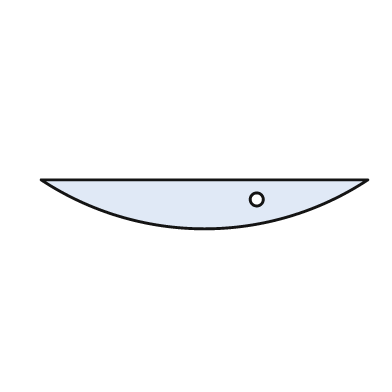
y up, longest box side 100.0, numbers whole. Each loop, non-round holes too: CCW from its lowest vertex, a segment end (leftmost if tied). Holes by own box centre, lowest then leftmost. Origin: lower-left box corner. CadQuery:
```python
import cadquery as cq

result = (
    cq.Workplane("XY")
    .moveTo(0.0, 15.0)
    .threePointArc((50.0, 0.0), (100.0, 15.0))
    .close()
    .moveTo(66.0, 9.0)
    .circle(2.0)
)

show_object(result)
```